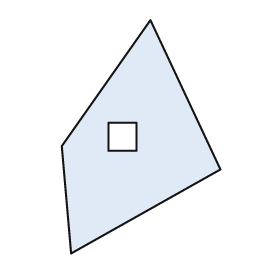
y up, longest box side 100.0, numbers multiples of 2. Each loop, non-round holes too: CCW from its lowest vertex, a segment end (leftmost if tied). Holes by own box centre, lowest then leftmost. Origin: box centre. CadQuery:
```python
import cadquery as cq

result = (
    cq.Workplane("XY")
    .moveTo(-30.0, -50.0)
    .lineTo(34.0, -14.0)
    .lineTo(4.0, 50.0)
    .lineTo(-34.0, -4.0)
    .close()
    .moveTo(-14.0, -6.0)
    .lineTo(-2.0, -6.0)
    .lineTo(-2.0, 6.0)
    .lineTo(-14.0, 6.0)
    .close()
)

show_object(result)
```